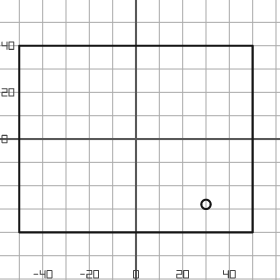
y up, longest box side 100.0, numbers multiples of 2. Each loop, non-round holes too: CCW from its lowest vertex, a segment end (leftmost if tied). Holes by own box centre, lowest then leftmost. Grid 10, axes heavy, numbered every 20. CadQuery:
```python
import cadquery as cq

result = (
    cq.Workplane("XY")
    .moveTo(-50.0, -40.0)
    .lineTo(50.0, -40.0)
    .lineTo(50.0, 40.0)
    .lineTo(-50.0, 40.0)
    .close()
    .moveTo(30.0, -28.0)
    .circle(2.0)
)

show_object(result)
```